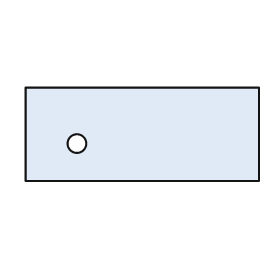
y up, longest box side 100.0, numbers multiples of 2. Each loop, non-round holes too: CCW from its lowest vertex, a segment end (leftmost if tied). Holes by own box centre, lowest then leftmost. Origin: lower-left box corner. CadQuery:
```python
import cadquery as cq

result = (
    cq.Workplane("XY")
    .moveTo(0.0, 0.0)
    .lineTo(100.0, 0.0)
    .lineTo(100.0, 40.0)
    .lineTo(0.0, 40.0)
    .close()
    .moveTo(22.0, 16.0)
    .circle(4.0)
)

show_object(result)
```